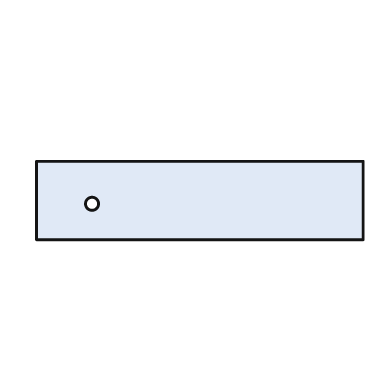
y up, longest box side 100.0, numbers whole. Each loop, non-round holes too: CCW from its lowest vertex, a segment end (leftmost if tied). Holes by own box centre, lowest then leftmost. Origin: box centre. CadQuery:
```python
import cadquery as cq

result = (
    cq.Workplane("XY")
    .moveTo(-50.0, -12.0)
    .lineTo(50.0, -12.0)
    .lineTo(50.0, 12.0)
    .lineTo(-50.0, 12.0)
    .close()
    .moveTo(-33.0, -1.0)
    .circle(2.0)
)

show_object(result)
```